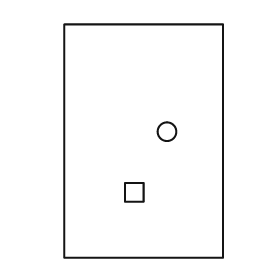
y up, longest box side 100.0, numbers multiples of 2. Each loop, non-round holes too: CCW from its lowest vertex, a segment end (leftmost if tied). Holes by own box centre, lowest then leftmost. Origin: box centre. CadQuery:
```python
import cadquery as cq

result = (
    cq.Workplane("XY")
    .moveTo(-34.0, -50.0)
    .lineTo(34.0, -50.0)
    .lineTo(34.0, 50.0)
    .lineTo(-34.0, 50.0)
    .close()
    .moveTo(-8.0, -26.0)
    .lineTo(0.0, -26.0)
    .lineTo(0.0, -18.0)
    .lineTo(-8.0, -18.0)
    .close()
    .moveTo(10.0, 4.0)
    .circle(4.0)
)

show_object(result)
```